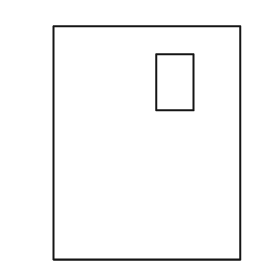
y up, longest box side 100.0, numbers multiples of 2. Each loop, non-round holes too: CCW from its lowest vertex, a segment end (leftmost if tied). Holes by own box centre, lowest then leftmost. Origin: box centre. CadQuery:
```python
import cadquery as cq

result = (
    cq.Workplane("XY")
    .moveTo(-40.0, -50.0)
    .lineTo(40.0, -50.0)
    .lineTo(40.0, 50.0)
    .lineTo(-40.0, 50.0)
    .close()
    .moveTo(4.0, 14.0)
    .lineTo(20.0, 14.0)
    .lineTo(20.0, 38.0)
    .lineTo(4.0, 38.0)
    .close()
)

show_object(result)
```